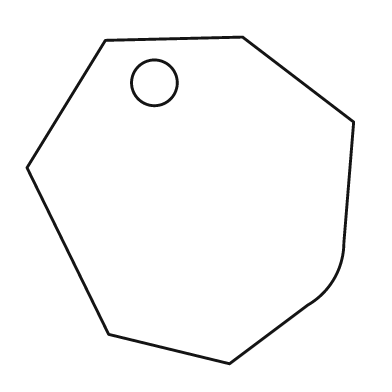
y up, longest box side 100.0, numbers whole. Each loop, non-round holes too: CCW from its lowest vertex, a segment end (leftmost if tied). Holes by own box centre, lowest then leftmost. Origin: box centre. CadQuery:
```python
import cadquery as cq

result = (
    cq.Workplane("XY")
    .moveTo(12.0, -50.0)
    .lineTo(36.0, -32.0)
    .threePointArc((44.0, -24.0), (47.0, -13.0))
    .lineTo(50.0, 24.0)
    .lineTo(16.0, 50.0)
    .lineTo(-26.0, 49.0)
    .lineTo(-50.0, 10.0)
    .lineTo(-25.0, -41.0)
    .close()
    .moveTo(-11.0, 36.0)
    .circle(7.0)
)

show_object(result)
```